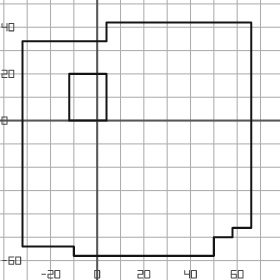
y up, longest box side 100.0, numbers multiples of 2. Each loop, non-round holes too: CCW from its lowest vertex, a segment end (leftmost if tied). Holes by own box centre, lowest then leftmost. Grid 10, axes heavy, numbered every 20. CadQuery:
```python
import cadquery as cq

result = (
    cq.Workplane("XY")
    .moveTo(-10.0, -58.0)
    .lineTo(50.0, -58.0)
    .lineTo(50.0, -50.0)
    .lineTo(58.0, -50.0)
    .lineTo(58.0, -46.0)
    .lineTo(66.0, -46.0)
    .lineTo(66.0, 42.0)
    .lineTo(4.0, 42.0)
    .lineTo(4.0, 34.0)
    .lineTo(-32.0, 34.0)
    .lineTo(-32.0, -54.0)
    .lineTo(-10.0, -54.0)
    .close()
    .moveTo(-12.0, 0.0)
    .lineTo(4.0, 0.0)
    .lineTo(4.0, 20.0)
    .lineTo(-12.0, 20.0)
    .close()
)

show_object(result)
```